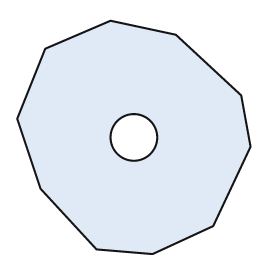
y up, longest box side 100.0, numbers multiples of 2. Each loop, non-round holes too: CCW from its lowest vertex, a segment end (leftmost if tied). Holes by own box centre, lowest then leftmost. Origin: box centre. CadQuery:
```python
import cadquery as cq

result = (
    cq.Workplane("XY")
    .moveTo(8.0, -50.0)
    .lineTo(34.0, -38.0)
    .lineTo(50.0, -4.0)
    .lineTo(46.0, 18.0)
    .lineTo(18.0, 44.0)
    .lineTo(-10.0, 50.0)
    .lineTo(-38.0, 38.0)
    .lineTo(-50.0, 8.0)
    .lineTo(-40.0, -22.0)
    .lineTo(-16.0, -48.0)
    .close()
    .moveTo(0.0, 0.0)
    .circle(10.0)
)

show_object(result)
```